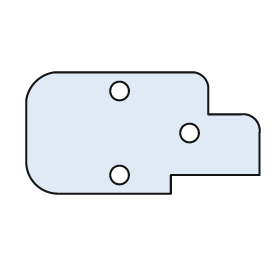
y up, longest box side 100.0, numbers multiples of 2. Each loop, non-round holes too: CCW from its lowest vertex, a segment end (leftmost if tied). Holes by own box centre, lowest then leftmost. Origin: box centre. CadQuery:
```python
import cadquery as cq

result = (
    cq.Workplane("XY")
    .moveTo(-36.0, -26.0)
    .lineTo(12.0, -26.0)
    .lineTo(12.0, -18.0)
    .lineTo(50.0, -18.0)
    .lineTo(50.0, 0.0)
    .threePointArc((48.0, 6.0), (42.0, 8.0))
    .lineTo(28.0, 8.0)
    .lineTo(28.0, 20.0)
    .threePointArc((26.0, 24.0), (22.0, 26.0))
    .lineTo(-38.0, 26.0)
    .threePointArc((-46.0, 22.0), (-50.0, 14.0))
    .lineTo(-50.0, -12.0)
    .threePointArc((-46.0, -22.0), (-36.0, -26.0))
    .close()
    .moveTo(-10.0, -18.0)
    .circle(4.0)
    .moveTo(20.0, 0.0)
    .circle(4.0)
    .moveTo(-10.0, 18.0)
    .circle(4.0)
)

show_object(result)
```